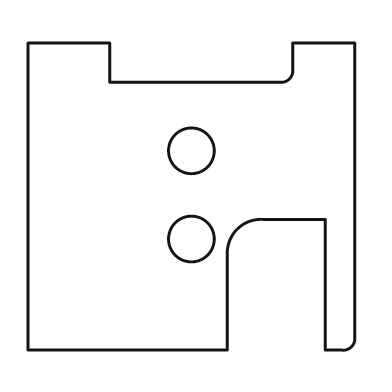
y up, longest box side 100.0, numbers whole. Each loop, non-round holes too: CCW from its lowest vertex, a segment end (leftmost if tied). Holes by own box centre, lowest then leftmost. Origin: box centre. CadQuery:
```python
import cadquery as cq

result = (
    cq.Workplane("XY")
    .moveTo(-50.0, -47.0)
    .lineTo(11.0, -47.0)
    .lineTo(11.0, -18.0)
    .threePointArc((14.0, -10.0), (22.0, -7.0))
    .lineTo(41.0, -7.0)
    .lineTo(41.0, -47.0)
    .lineTo(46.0, -47.0)
    .threePointArc((49.0, -46.0), (50.0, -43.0))
    .lineTo(50.0, 47.0)
    .lineTo(31.0, 47.0)
    .lineTo(31.0, 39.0)
    .threePointArc((30.0, 36.0), (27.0, 35.0))
    .lineTo(-25.0, 35.0)
    .lineTo(-25.0, 47.0)
    .lineTo(-50.0, 47.0)
    .close()
    .moveTo(0.0, -13.0)
    .circle(7.0)
    .moveTo(0.0, 14.0)
    .circle(7.0)
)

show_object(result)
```